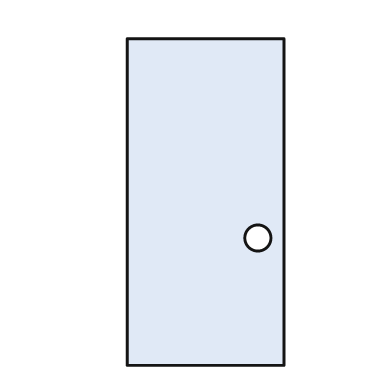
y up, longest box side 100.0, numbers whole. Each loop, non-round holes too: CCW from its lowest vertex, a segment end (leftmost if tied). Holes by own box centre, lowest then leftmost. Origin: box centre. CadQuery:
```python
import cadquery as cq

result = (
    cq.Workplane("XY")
    .moveTo(-24.0, -50.0)
    .lineTo(24.0, -50.0)
    .lineTo(24.0, 50.0)
    .lineTo(-24.0, 50.0)
    .close()
    .moveTo(16.0, -11.0)
    .circle(4.0)
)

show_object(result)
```